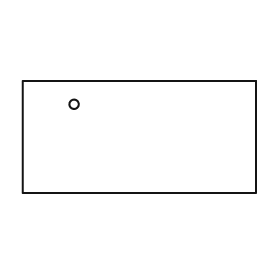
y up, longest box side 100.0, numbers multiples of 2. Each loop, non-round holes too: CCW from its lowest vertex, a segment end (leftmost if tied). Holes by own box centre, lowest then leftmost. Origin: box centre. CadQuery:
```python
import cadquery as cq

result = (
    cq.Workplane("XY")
    .moveTo(-50.0, -24.0)
    .lineTo(50.0, -24.0)
    .lineTo(50.0, 24.0)
    .lineTo(-50.0, 24.0)
    .close()
    .moveTo(-28.0, 14.0)
    .circle(2.0)
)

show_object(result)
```